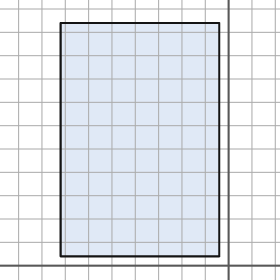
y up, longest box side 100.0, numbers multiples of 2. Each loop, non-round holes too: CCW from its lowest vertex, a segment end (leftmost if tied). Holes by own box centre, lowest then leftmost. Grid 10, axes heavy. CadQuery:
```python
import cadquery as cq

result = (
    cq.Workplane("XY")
    .moveTo(-72.0, 4.0)
    .lineTo(-4.0, 4.0)
    .lineTo(-4.0, 104.0)
    .lineTo(-72.0, 104.0)
    .close()
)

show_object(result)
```